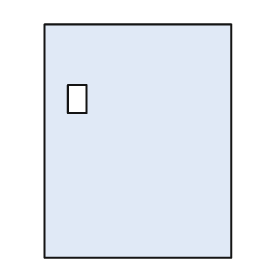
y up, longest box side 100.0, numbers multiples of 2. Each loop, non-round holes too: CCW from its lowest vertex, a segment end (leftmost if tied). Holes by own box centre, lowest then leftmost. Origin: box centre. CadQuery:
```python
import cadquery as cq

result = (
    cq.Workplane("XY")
    .moveTo(-40.0, -50.0)
    .lineTo(40.0, -50.0)
    .lineTo(40.0, 50.0)
    .lineTo(-40.0, 50.0)
    .close()
    .moveTo(-30.0, 12.0)
    .lineTo(-22.0, 12.0)
    .lineTo(-22.0, 24.0)
    .lineTo(-30.0, 24.0)
    .close()
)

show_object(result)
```